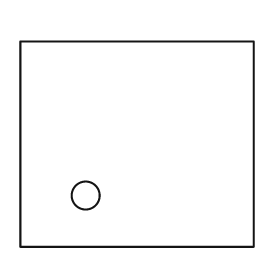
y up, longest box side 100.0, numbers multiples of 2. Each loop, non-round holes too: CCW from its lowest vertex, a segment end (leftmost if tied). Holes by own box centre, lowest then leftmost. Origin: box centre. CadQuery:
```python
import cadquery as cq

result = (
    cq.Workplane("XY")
    .moveTo(-50.0, -44.0)
    .lineTo(50.0, -44.0)
    .lineTo(50.0, 44.0)
    .lineTo(-50.0, 44.0)
    .close()
    .moveTo(-22.0, -22.0)
    .circle(6.0)
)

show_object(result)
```